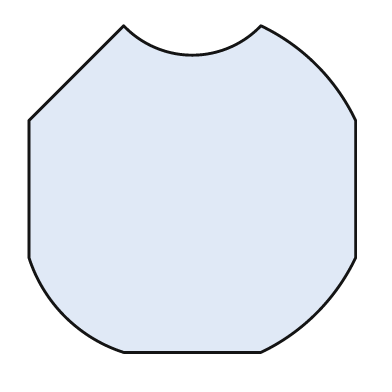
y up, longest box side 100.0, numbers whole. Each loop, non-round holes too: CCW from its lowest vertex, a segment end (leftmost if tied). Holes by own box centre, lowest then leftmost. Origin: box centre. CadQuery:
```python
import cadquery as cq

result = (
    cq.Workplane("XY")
    .moveTo(-21.0, -50.0)
    .lineTo(21.0, -50.0)
    .threePointArc((38.0, -38.0), (50.0, -21.0))
    .lineTo(50.0, 21.0)
    .threePointArc((38.0, 38.0), (21.0, 50.0))
    .threePointArc((0.0, 41.0), (-21.0, 50.0))
    .lineTo(-50.0, 21.0)
    .lineTo(-50.0, -21.0)
    .threePointArc((-39.0, -39.0), (-21.0, -50.0))
    .close()
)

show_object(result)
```